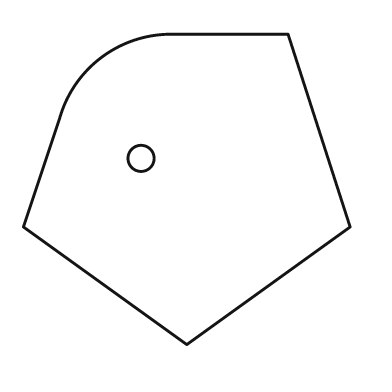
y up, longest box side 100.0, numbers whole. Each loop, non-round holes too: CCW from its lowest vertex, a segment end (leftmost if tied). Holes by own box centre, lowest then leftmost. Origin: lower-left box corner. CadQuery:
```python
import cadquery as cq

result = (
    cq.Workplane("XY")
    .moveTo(50.0, 0.0)
    .lineTo(100.0, 36.0)
    .lineTo(81.0, 95.0)
    .lineTo(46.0, 95.0)
    .threePointArc((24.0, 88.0), (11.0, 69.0))
    .lineTo(0.0, 36.0)
    .close()
    .moveTo(36.0, 57.0)
    .circle(4.0)
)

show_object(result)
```